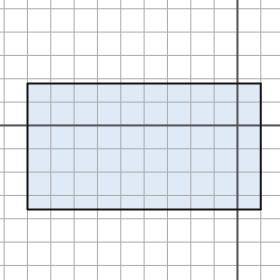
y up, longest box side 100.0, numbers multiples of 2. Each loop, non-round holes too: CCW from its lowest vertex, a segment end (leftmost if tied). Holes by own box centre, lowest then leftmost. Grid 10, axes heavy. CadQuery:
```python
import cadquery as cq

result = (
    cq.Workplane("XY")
    .moveTo(-90.0, -36.0)
    .lineTo(10.0, -36.0)
    .lineTo(10.0, 18.0)
    .lineTo(-90.0, 18.0)
    .close()
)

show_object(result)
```